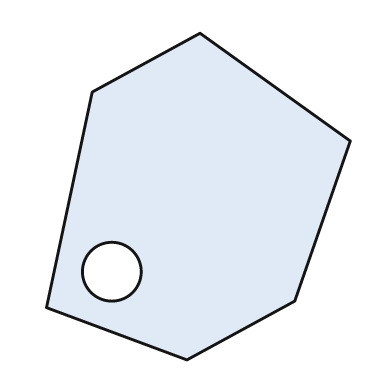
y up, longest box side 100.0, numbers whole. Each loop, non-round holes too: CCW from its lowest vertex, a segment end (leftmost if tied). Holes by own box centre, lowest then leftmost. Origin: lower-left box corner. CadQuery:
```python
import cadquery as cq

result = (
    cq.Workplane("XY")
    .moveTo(43.0, 0.0)
    .lineTo(76.0, 18.0)
    .lineTo(93.0, 67.0)
    .lineTo(47.0, 100.0)
    .lineTo(14.0, 82.0)
    .lineTo(0.0, 16.0)
    .close()
    .moveTo(20.0, 27.0)
    .circle(9.0)
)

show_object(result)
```